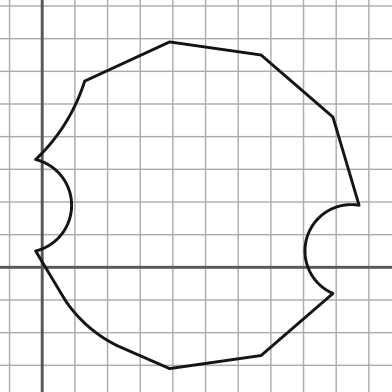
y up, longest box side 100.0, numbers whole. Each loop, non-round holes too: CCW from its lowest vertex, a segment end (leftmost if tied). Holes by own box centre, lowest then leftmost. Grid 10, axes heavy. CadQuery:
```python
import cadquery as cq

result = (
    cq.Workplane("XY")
    .moveTo(39.0, -31.0)
    .lineTo(67.0, -27.0)
    .lineTo(89.0, -8.0)
    .threePointArc((81.0, 9.0), (97.0, 19.0))
    .lineTo(89.0, 46.0)
    .lineTo(67.0, 65.0)
    .lineTo(39.0, 69.0)
    .lineTo(13.0, 57.0)
    .threePointArc((7.0, 44.0), (-2.0, 33.0))
    .threePointArc((9.0, 19.0), (-2.0, 5.0))
    .lineTo(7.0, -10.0)
    .threePointArc((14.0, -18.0), (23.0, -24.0))
    .close()
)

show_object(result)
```